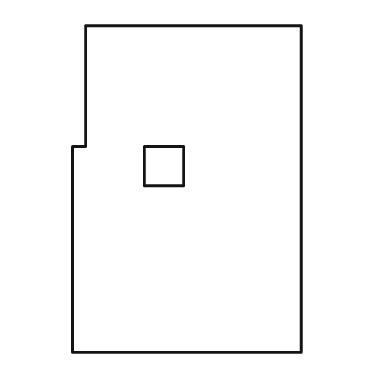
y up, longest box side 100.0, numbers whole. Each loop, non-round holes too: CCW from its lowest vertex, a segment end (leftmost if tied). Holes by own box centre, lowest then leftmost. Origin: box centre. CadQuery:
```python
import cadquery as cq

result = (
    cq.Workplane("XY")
    .moveTo(-35.0, -50.0)
    .lineTo(35.0, -50.0)
    .lineTo(35.0, 50.0)
    .lineTo(-31.0, 50.0)
    .lineTo(-31.0, 13.0)
    .lineTo(-35.0, 13.0)
    .close()
    .moveTo(-13.0, 1.0)
    .lineTo(-1.0, 1.0)
    .lineTo(-1.0, 13.0)
    .lineTo(-13.0, 13.0)
    .close()
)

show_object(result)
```